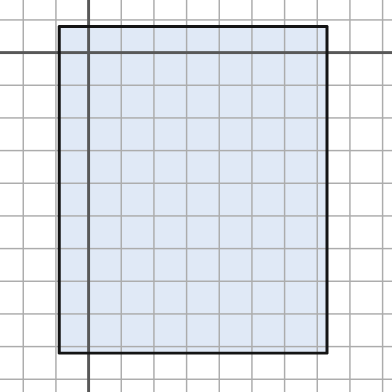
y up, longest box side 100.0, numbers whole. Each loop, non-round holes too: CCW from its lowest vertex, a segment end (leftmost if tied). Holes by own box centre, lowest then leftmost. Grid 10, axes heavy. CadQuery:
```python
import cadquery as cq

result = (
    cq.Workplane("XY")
    .moveTo(-9.0, -92.0)
    .lineTo(73.0, -92.0)
    .lineTo(73.0, 8.0)
    .lineTo(-9.0, 8.0)
    .close()
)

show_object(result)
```